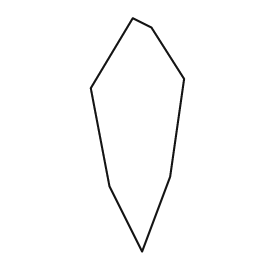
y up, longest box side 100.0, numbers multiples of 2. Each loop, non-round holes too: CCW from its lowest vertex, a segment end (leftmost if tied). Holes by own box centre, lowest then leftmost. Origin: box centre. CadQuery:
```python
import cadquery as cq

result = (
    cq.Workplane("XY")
    .moveTo(2.0, -50.0)
    .lineTo(14.0, -18.0)
    .lineTo(20.0, 24.0)
    .lineTo(6.0, 46.0)
    .lineTo(-2.0, 50.0)
    .lineTo(-20.0, 20.0)
    .lineTo(-12.0, -22.0)
    .close()
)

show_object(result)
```